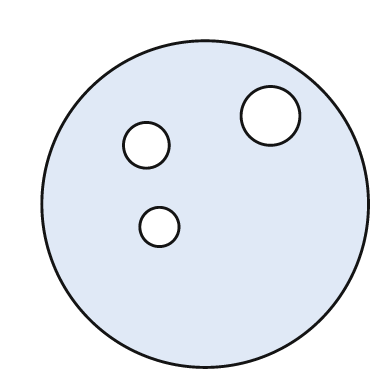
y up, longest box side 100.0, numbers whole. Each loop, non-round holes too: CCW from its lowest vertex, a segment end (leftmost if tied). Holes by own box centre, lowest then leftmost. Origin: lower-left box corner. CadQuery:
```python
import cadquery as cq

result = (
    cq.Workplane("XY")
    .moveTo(50.0, 50.0)
    .circle(50.0)
    .moveTo(36.0, 43.0)
    .circle(6.0)
    .moveTo(32.0, 68.0)
    .circle(7.0)
    .moveTo(70.0, 77.0)
    .circle(9.0)
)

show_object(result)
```